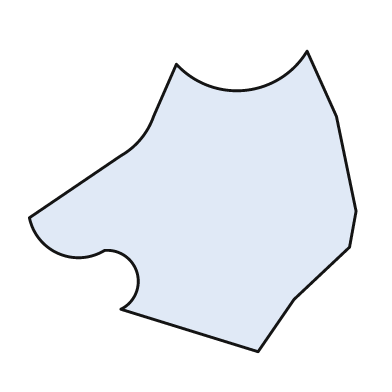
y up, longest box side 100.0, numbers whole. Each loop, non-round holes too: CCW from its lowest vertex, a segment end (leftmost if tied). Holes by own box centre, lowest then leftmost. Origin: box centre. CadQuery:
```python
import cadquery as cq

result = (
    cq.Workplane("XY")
    .moveTo(20.0, -46.0)
    .lineTo(31.0, -30.0)
    .lineTo(48.0, -14.0)
    .lineTo(50.0, -3.0)
    .lineTo(44.0, 26.0)
    .lineTo(35.0, 46.0)
    .threePointArc((16.0, 34.0), (-5.0, 42.0))
    .lineTo(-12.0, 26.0)
    .threePointArc((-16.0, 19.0), (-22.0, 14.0))
    .lineTo(-50.0, -5.0)
    .threePointArc((-41.0, -16.0), (-27.0, -15.0))
    .threePointArc((-17.0, -22.0), (-22.0, -33.0))
    .close()
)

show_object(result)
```